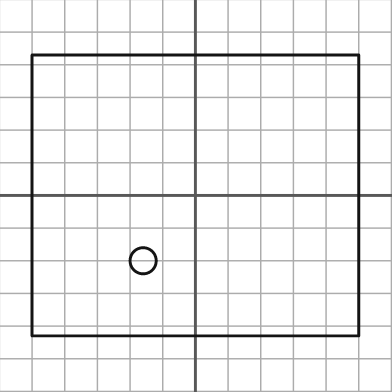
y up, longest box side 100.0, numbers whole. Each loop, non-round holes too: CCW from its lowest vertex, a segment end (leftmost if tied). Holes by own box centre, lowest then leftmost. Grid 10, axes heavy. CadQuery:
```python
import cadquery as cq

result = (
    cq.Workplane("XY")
    .moveTo(-50.0, -43.0)
    .lineTo(50.0, -43.0)
    .lineTo(50.0, 43.0)
    .lineTo(-50.0, 43.0)
    .close()
    .moveTo(-16.0, -20.0)
    .circle(4.0)
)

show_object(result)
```